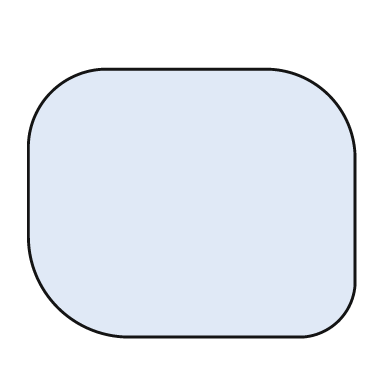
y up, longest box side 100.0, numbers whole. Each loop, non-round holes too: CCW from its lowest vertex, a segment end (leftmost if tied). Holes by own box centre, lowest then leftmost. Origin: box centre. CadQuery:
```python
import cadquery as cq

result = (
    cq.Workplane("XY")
    .moveTo(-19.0, -41.0)
    .lineTo(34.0, -41.0)
    .threePointArc((45.0, -36.0), (50.0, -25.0))
    .lineTo(50.0, 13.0)
    .threePointArc((42.0, 33.0), (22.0, 41.0))
    .lineTo(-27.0, 41.0)
    .threePointArc((-43.0, 34.0), (-50.0, 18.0))
    .lineTo(-50.0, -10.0)
    .threePointArc((-41.0, -32.0), (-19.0, -41.0))
    .close()
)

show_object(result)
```